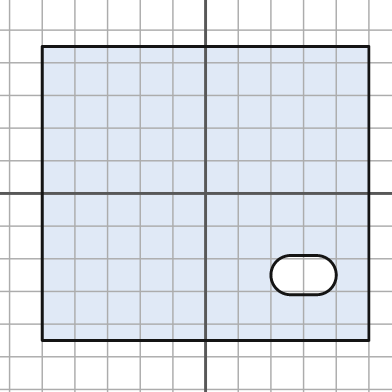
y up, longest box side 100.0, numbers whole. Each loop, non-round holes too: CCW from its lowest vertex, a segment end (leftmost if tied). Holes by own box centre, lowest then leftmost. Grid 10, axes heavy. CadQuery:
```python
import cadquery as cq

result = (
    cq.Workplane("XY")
    .moveTo(-50.0, -45.0)
    .lineTo(50.0, -45.0)
    .lineTo(50.0, 45.0)
    .lineTo(-50.0, 45.0)
    .close()
    .moveTo(26.0, -31.0)
    .lineTo(34.0, -31.0)
    .threePointArc((40.0, -25.0), (34.0, -19.0))
    .lineTo(26.0, -19.0)
    .threePointArc((20.0, -25.0), (26.0, -31.0))
    .close()
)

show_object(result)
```